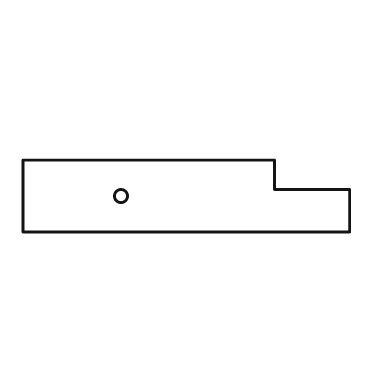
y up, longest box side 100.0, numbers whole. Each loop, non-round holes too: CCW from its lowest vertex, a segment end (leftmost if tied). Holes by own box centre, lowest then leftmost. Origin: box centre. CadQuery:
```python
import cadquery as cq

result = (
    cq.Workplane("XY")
    .moveTo(-50.0, -11.0)
    .lineTo(50.0, -11.0)
    .lineTo(50.0, 2.0)
    .lineTo(27.0, 2.0)
    .lineTo(27.0, 11.0)
    .lineTo(-50.0, 11.0)
    .close()
    .moveTo(-20.0, 0.0)
    .circle(2.0)
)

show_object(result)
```